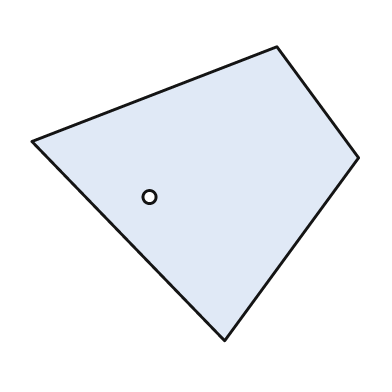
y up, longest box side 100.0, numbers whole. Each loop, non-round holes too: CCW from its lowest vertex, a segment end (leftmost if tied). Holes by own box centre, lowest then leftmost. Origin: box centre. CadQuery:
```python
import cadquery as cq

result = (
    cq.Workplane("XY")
    .moveTo(9.0, -45.0)
    .lineTo(50.0, 11.0)
    .lineTo(25.0, 45.0)
    .lineTo(-50.0, 16.0)
    .close()
    .moveTo(-14.0, -1.0)
    .circle(2.0)
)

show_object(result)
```